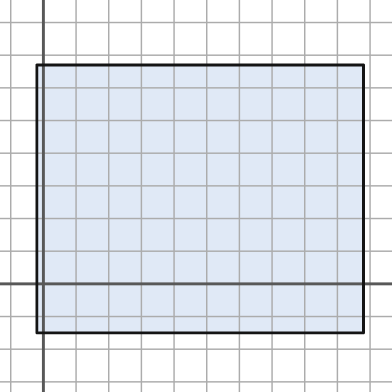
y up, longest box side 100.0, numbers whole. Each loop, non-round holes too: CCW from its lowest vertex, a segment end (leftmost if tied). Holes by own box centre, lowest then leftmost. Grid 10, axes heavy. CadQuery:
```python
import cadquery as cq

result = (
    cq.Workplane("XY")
    .moveTo(-2.0, -15.0)
    .lineTo(98.0, -15.0)
    .lineTo(98.0, 67.0)
    .lineTo(-2.0, 67.0)
    .close()
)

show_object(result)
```